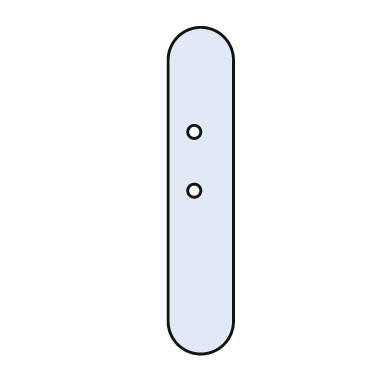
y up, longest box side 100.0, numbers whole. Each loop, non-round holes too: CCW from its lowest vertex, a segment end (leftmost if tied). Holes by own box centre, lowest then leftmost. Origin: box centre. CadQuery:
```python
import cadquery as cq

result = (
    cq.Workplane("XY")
    .moveTo(-10.0, -40.0)
    .threePointArc((0.0, -50.0), (10.0, -40.0))
    .lineTo(10.0, 40.0)
    .threePointArc((0.0, 50.0), (-10.0, 40.0))
    .close()
    .moveTo(-2.0, 0.0)
    .circle(2.0)
    .moveTo(-2.0, 18.0)
    .circle(2.0)
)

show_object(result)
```